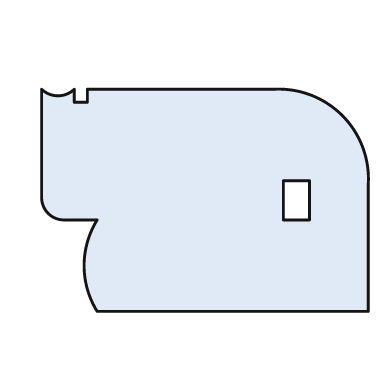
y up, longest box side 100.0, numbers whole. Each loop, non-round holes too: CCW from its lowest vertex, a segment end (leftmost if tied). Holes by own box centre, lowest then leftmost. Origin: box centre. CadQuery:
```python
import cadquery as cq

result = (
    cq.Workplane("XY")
    .moveTo(-33.0, -34.0)
    .lineTo(50.0, -34.0)
    .lineTo(50.0, 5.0)
    .threePointArc((42.0, 26.0), (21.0, 34.0))
    .lineTo(-36.0, 34.0)
    .lineTo(-36.0, 30.0)
    .lineTo(-40.0, 30.0)
    .lineTo(-40.0, 34.0)
    .threePointArc((-45.0, 32.0), (-50.0, 34.0))
    .lineTo(-50.0, 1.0)
    .threePointArc((-48.0, -4.0), (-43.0, -6.0))
    .lineTo(-33.0, -6.0)
    .threePointArc((-37.0, -20.0), (-33.0, -34.0))
    .close()
    .moveTo(24.0, -6.0)
    .lineTo(32.0, -6.0)
    .lineTo(32.0, 6.0)
    .lineTo(24.0, 6.0)
    .close()
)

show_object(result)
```